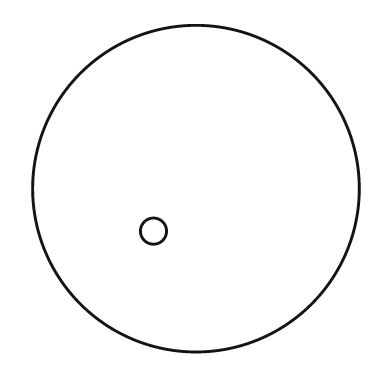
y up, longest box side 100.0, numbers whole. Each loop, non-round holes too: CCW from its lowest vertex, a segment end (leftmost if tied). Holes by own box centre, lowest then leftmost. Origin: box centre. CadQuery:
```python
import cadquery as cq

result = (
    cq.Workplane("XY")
    .moveTo(0.0, 0.0)
    .circle(50.0)
    .moveTo(-13.0, -13.0)
    .circle(4.0)
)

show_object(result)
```